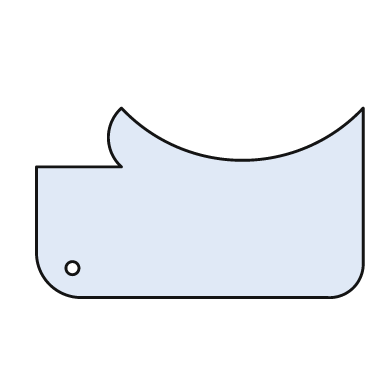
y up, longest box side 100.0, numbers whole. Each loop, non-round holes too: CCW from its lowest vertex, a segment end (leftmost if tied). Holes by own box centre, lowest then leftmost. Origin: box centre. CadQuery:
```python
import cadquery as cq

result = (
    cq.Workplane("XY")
    .moveTo(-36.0, -29.0)
    .lineTo(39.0, -29.0)
    .threePointArc((47.0, -26.0), (50.0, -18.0))
    .lineTo(50.0, 29.0)
    .threePointArc((13.0, 13.0), (-24.0, 29.0))
    .threePointArc((-28.0, 20.0), (-24.0, 11.0))
    .lineTo(-50.0, 11.0)
    .lineTo(-50.0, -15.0)
    .threePointArc((-46.0, -25.0), (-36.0, -29.0))
    .close()
    .moveTo(-39.0, -20.0)
    .circle(2.0)
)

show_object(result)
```